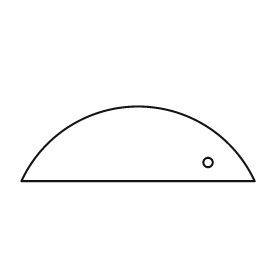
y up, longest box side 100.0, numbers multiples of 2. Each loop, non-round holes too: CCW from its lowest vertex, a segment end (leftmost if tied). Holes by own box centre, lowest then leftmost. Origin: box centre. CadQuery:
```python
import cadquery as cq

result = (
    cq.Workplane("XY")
    .moveTo(-50.0, -16.0)
    .lineTo(50.0, -16.0)
    .threePointArc((0.0, 16.0), (-50.0, -16.0))
    .close()
    .moveTo(30.0, -8.0)
    .circle(2.0)
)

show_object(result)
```